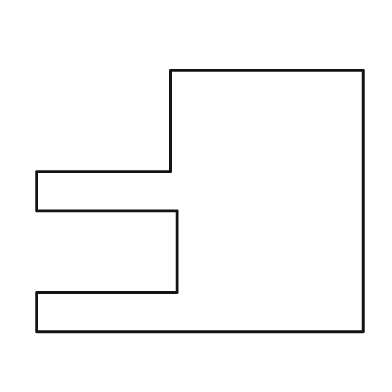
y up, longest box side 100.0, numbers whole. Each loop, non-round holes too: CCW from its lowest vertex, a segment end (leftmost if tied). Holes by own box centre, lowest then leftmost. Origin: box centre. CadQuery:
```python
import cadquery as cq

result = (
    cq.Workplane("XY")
    .moveTo(-50.0, -40.0)
    .lineTo(50.0, -40.0)
    .lineTo(50.0, 40.0)
    .lineTo(-9.0, 40.0)
    .lineTo(-9.0, 9.0)
    .lineTo(-50.0, 9.0)
    .lineTo(-50.0, -3.0)
    .lineTo(-7.0, -3.0)
    .lineTo(-7.0, -28.0)
    .lineTo(-50.0, -28.0)
    .close()
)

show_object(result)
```